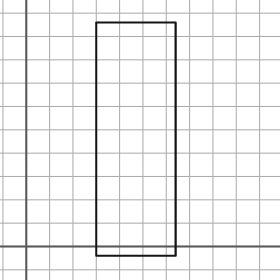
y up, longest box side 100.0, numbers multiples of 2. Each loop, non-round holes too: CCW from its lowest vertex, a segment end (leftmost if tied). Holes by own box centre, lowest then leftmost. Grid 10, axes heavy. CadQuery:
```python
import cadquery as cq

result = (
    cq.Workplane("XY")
    .moveTo(30.0, -4.0)
    .lineTo(64.0, -4.0)
    .lineTo(64.0, 96.0)
    .lineTo(30.0, 96.0)
    .close()
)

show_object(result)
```